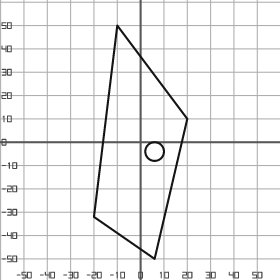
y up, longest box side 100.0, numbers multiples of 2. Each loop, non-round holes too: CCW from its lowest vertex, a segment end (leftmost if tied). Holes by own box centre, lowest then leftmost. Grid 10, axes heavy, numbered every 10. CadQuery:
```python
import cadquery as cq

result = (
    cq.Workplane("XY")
    .moveTo(6.0, -50.0)
    .lineTo(20.0, 10.0)
    .lineTo(-10.0, 50.0)
    .lineTo(-20.0, -32.0)
    .close()
    .moveTo(6.0, -4.0)
    .circle(4.0)
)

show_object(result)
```